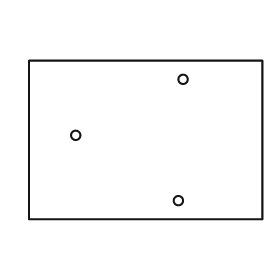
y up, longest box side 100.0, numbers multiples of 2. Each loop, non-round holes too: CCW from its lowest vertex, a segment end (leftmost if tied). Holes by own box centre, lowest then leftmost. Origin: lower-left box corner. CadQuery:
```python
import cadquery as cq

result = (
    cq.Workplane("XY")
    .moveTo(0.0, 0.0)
    .lineTo(100.0, 0.0)
    .lineTo(100.0, 68.0)
    .lineTo(0.0, 68.0)
    .close()
    .moveTo(64.0, 8.0)
    .circle(2.0)
    .moveTo(20.0, 36.0)
    .circle(2.0)
    .moveTo(66.0, 60.0)
    .circle(2.0)
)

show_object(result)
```